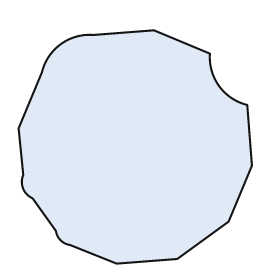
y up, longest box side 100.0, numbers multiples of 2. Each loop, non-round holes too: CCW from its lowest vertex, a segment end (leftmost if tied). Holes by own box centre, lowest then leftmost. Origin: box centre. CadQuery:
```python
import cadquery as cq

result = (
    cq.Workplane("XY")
    .moveTo(-8.0, -50.0)
    .lineTo(18.0, -48.0)
    .lineTo(40.0, -32.0)
    .lineTo(50.0, -8.0)
    .lineTo(48.0, 18.0)
    .threePointArc((36.0, 26.0), (32.0, 40.0))
    .lineTo(8.0, 50.0)
    .lineTo(-18.0, 48.0)
    .threePointArc((-32.0, 44.0), (-40.0, 32.0))
    .lineTo(-50.0, 8.0)
    .lineTo(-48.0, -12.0)
    .threePointArc((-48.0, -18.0), (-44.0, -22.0))
    .lineTo(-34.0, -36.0)
    .threePointArc((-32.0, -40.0), (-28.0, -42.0))
    .close()
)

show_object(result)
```